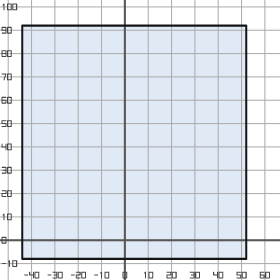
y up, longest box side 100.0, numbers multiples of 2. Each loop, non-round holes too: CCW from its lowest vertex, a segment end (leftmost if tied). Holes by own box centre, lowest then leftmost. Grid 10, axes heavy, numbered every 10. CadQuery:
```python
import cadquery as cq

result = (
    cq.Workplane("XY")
    .moveTo(-44.0, -8.0)
    .lineTo(52.0, -8.0)
    .lineTo(52.0, 92.0)
    .lineTo(-44.0, 92.0)
    .close()
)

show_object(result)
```